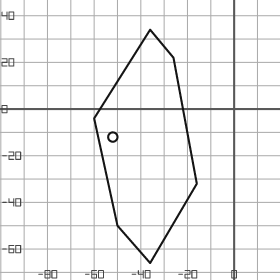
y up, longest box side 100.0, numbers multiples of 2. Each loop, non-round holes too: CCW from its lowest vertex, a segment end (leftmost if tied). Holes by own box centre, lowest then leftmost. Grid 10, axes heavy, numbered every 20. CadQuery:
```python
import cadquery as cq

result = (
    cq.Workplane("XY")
    .moveTo(-36.0, -66.0)
    .lineTo(-16.0, -32.0)
    .lineTo(-26.0, 22.0)
    .lineTo(-36.0, 34.0)
    .lineTo(-60.0, -4.0)
    .lineTo(-50.0, -50.0)
    .close()
    .moveTo(-52.0, -12.0)
    .circle(2.0)
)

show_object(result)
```